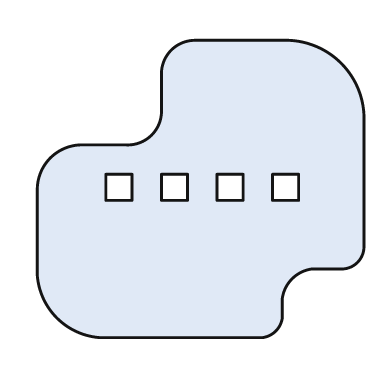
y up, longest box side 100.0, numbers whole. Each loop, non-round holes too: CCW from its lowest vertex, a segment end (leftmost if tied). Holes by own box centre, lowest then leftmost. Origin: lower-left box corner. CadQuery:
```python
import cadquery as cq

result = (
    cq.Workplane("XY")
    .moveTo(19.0, 0.0)
    .lineTo(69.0, 0.0)
    .threePointArc((73.0, 2.0), (75.0, 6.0))
    .lineTo(75.0, 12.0)
    .threePointArc((78.0, 18.0), (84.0, 21.0))
    .lineTo(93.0, 21.0)
    .threePointArc((98.0, 23.0), (100.0, 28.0))
    .lineTo(100.0, 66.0)
    .threePointArc((93.0, 84.0), (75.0, 91.0))
    .lineTo(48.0, 91.0)
    .threePointArc((41.0, 88.0), (38.0, 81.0))
    .lineTo(38.0, 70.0)
    .threePointArc((35.0, 62.0), (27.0, 59.0))
    .lineTo(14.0, 59.0)
    .threePointArc((4.0, 55.0), (0.0, 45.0))
    .lineTo(0.0, 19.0)
    .threePointArc((6.0, 6.0), (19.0, 0.0))
    .close()
    .moveTo(21.0, 42.0)
    .lineTo(29.0, 42.0)
    .lineTo(29.0, 50.0)
    .lineTo(21.0, 50.0)
    .close()
    .moveTo(38.0, 42.0)
    .lineTo(46.0, 42.0)
    .lineTo(46.0, 50.0)
    .lineTo(38.0, 50.0)
    .close()
    .moveTo(55.0, 42.0)
    .lineTo(63.0, 42.0)
    .lineTo(63.0, 50.0)
    .lineTo(55.0, 50.0)
    .close()
    .moveTo(72.0, 42.0)
    .lineTo(80.0, 42.0)
    .lineTo(80.0, 50.0)
    .lineTo(72.0, 50.0)
    .close()
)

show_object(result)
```